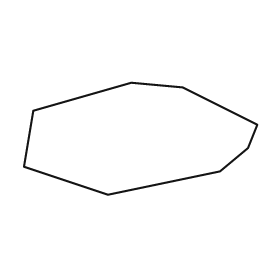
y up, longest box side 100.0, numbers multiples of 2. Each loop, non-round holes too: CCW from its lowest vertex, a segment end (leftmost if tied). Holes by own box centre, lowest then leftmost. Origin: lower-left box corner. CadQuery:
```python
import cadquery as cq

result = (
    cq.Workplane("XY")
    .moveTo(36.0, 0.0)
    .lineTo(84.0, 10.0)
    .lineTo(96.0, 20.0)
    .lineTo(100.0, 30.0)
    .lineTo(68.0, 46.0)
    .lineTo(46.0, 48.0)
    .lineTo(4.0, 36.0)
    .lineTo(0.0, 12.0)
    .close()
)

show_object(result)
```